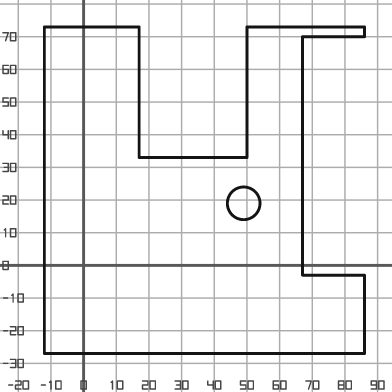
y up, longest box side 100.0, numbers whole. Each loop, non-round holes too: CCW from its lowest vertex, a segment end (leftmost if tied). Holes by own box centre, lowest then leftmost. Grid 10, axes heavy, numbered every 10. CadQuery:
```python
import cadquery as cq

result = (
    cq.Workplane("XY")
    .moveTo(-12.0, -27.0)
    .lineTo(86.0, -27.0)
    .lineTo(86.0, -3.0)
    .lineTo(67.0, -3.0)
    .lineTo(67.0, 70.0)
    .lineTo(86.0, 70.0)
    .lineTo(86.0, 73.0)
    .lineTo(50.0, 73.0)
    .lineTo(50.0, 33.0)
    .lineTo(17.0, 33.0)
    .lineTo(17.0, 73.0)
    .lineTo(-12.0, 73.0)
    .close()
    .moveTo(49.0, 19.0)
    .circle(5.0)
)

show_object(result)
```